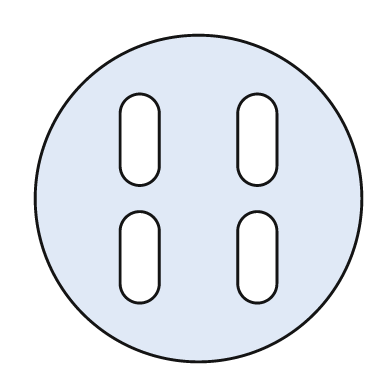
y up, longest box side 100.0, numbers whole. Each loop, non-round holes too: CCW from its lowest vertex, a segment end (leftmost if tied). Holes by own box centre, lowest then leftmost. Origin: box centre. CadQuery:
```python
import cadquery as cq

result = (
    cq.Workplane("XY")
    .moveTo(0.0, 0.0)
    .circle(50.0)
    .moveTo(-24.0, -26.0)
    .threePointArc((-18.0, -32.0), (-12.0, -26.0))
    .lineTo(-12.0, -10.0)
    .threePointArc((-18.0, -4.0), (-24.0, -10.0))
    .close()
    .moveTo(12.0, -26.0)
    .threePointArc((18.0, -32.0), (24.0, -26.0))
    .lineTo(24.0, -10.0)
    .threePointArc((18.0, -4.0), (12.0, -10.0))
    .close()
    .moveTo(-24.0, 10.0)
    .threePointArc((-18.0, 4.0), (-12.0, 10.0))
    .lineTo(-12.0, 26.0)
    .threePointArc((-18.0, 32.0), (-24.0, 26.0))
    .close()
    .moveTo(12.0, 10.0)
    .threePointArc((18.0, 4.0), (24.0, 10.0))
    .lineTo(24.0, 26.0)
    .threePointArc((18.0, 32.0), (12.0, 26.0))
    .close()
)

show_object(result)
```